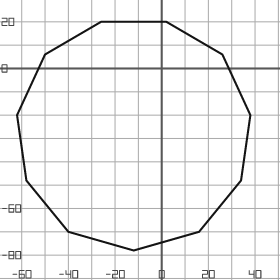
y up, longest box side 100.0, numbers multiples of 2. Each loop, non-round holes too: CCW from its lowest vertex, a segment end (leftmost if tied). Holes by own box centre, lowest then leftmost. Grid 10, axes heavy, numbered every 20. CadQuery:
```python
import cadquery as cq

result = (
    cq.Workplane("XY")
    .moveTo(-12.0, -78.0)
    .lineTo(16.0, -70.0)
    .lineTo(34.0, -48.0)
    .lineTo(38.0, -20.0)
    .lineTo(26.0, 6.0)
    .lineTo(2.0, 20.0)
    .lineTo(-26.0, 20.0)
    .lineTo(-50.0, 6.0)
    .lineTo(-62.0, -20.0)
    .lineTo(-58.0, -48.0)
    .lineTo(-40.0, -70.0)
    .close()
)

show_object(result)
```